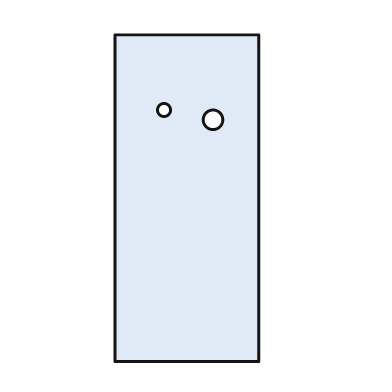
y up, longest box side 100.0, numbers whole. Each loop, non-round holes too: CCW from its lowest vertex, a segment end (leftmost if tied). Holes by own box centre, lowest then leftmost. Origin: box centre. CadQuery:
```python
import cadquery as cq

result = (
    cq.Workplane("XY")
    .moveTo(-22.0, -50.0)
    .lineTo(22.0, -50.0)
    .lineTo(22.0, 50.0)
    .lineTo(-22.0, 50.0)
    .close()
    .moveTo(8.0, 24.0)
    .circle(3.0)
    .moveTo(-7.0, 27.0)
    .circle(2.0)
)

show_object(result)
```